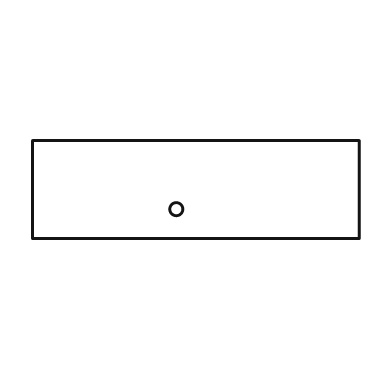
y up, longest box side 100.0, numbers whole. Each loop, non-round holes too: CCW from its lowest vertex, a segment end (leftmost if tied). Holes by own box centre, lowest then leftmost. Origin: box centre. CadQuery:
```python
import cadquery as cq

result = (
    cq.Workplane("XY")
    .moveTo(-50.0, -15.0)
    .lineTo(50.0, -15.0)
    .lineTo(50.0, 15.0)
    .lineTo(-50.0, 15.0)
    .close()
    .moveTo(-6.0, -6.0)
    .circle(2.0)
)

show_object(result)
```